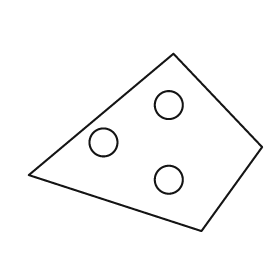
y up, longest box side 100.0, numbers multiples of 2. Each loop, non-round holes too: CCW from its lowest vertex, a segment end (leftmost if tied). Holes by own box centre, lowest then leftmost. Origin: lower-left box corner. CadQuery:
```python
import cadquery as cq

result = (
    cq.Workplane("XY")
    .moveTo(74.0, 0.0)
    .lineTo(100.0, 36.0)
    .lineTo(62.0, 76.0)
    .lineTo(0.0, 24.0)
    .close()
    .moveTo(60.0, 22.0)
    .circle(6.0)
    .moveTo(32.0, 38.0)
    .circle(6.0)
    .moveTo(60.0, 54.0)
    .circle(6.0)
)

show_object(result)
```